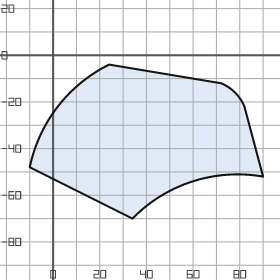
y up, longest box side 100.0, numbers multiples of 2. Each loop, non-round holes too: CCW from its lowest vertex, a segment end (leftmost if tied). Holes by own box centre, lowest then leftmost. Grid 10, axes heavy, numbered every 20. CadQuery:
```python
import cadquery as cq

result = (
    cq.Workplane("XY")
    .moveTo(34.0, -70.0)
    .threePointArc((60.0, -54.0), (90.0, -52.0))
    .lineTo(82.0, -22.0)
    .threePointArc((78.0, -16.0), (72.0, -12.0))
    .lineTo(24.0, -4.0)
    .threePointArc((2.0, -22.0), (-10.0, -48.0))
    .close()
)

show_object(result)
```